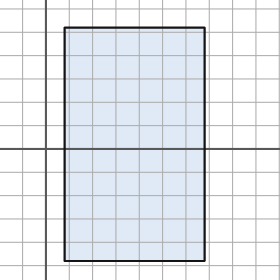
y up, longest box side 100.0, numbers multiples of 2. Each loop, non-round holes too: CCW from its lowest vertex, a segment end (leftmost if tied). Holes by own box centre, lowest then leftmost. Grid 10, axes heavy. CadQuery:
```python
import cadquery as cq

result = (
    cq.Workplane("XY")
    .moveTo(8.0, -48.0)
    .lineTo(68.0, -48.0)
    .lineTo(68.0, 52.0)
    .lineTo(8.0, 52.0)
    .close()
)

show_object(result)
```